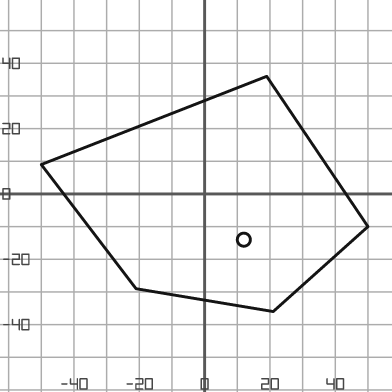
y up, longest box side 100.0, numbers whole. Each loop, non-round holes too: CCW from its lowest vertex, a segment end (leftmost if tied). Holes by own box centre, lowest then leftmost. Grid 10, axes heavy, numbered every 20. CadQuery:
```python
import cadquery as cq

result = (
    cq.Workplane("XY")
    .moveTo(21.0, -36.0)
    .lineTo(50.0, -10.0)
    .lineTo(19.0, 36.0)
    .lineTo(-50.0, 9.0)
    .lineTo(-21.0, -29.0)
    .close()
    .moveTo(12.0, -14.0)
    .circle(2.0)
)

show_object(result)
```